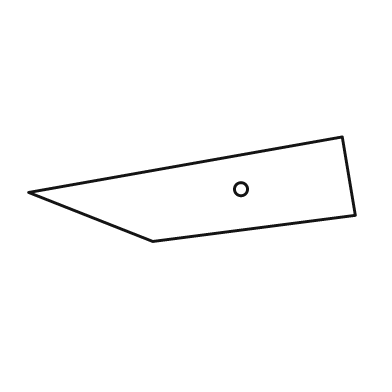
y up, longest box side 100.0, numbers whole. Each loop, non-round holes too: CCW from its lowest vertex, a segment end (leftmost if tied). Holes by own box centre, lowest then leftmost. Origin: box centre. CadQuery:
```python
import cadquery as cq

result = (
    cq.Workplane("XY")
    .moveTo(-12.0, -16.0)
    .lineTo(50.0, -8.0)
    .lineTo(46.0, 16.0)
    .lineTo(-50.0, -1.0)
    .close()
    .moveTo(15.0, 0.0)
    .circle(2.0)
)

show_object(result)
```